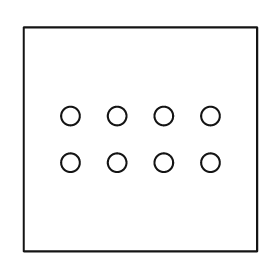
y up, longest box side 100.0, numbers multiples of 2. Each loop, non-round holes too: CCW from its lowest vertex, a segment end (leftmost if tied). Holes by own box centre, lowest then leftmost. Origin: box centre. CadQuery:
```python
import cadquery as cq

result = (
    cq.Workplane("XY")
    .moveTo(-50.0, -48.0)
    .lineTo(50.0, -48.0)
    .lineTo(50.0, 48.0)
    .lineTo(-50.0, 48.0)
    .close()
    .moveTo(-30.0, -10.0)
    .circle(4.0)
    .moveTo(-10.0, -10.0)
    .circle(4.0)
    .moveTo(10.0, -10.0)
    .circle(4.0)
    .moveTo(30.0, -10.0)
    .circle(4.0)
    .moveTo(-30.0, 10.0)
    .circle(4.0)
    .moveTo(-10.0, 10.0)
    .circle(4.0)
    .moveTo(10.0, 10.0)
    .circle(4.0)
    .moveTo(30.0, 10.0)
    .circle(4.0)
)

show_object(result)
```